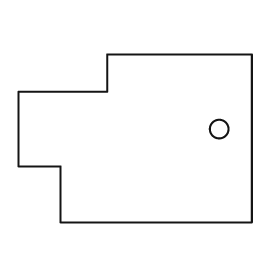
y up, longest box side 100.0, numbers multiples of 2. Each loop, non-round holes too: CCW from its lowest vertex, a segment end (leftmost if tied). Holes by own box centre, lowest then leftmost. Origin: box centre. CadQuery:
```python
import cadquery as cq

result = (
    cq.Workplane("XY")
    .moveTo(-32.0, -36.0)
    .lineTo(50.0, -36.0)
    .lineTo(50.0, 36.0)
    .lineTo(-12.0, 36.0)
    .lineTo(-12.0, 20.0)
    .lineTo(-50.0, 20.0)
    .lineTo(-50.0, -12.0)
    .lineTo(-32.0, -12.0)
    .close()
    .moveTo(36.0, 4.0)
    .circle(4.0)
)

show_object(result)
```